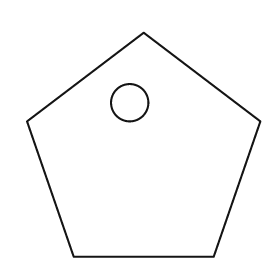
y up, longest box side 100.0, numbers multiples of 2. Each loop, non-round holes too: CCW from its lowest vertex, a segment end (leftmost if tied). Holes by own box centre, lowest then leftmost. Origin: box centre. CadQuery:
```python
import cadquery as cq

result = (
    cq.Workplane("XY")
    .moveTo(-30.0, -48.0)
    .lineTo(30.0, -48.0)
    .lineTo(50.0, 10.0)
    .lineTo(0.0, 48.0)
    .lineTo(-50.0, 10.0)
    .close()
    .moveTo(-6.0, 18.0)
    .circle(8.0)
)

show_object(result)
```